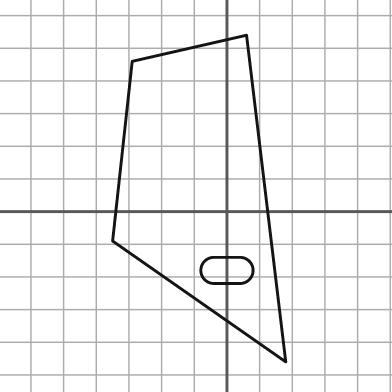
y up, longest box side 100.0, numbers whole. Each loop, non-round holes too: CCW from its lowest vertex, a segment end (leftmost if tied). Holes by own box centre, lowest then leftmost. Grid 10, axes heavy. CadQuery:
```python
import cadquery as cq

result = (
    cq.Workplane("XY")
    .moveTo(18.0, -46.0)
    .lineTo(6.0, 54.0)
    .lineTo(-29.0, 46.0)
    .lineTo(-35.0, -9.0)
    .close()
    .moveTo(-4.0, -22.0)
    .lineTo(4.0, -22.0)
    .threePointArc((8.0, -18.0), (4.0, -14.0))
    .lineTo(-4.0, -14.0)
    .threePointArc((-8.0, -18.0), (-4.0, -22.0))
    .close()
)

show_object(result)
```